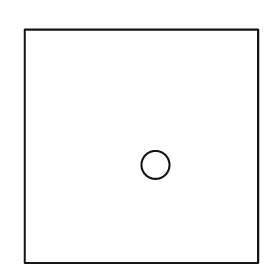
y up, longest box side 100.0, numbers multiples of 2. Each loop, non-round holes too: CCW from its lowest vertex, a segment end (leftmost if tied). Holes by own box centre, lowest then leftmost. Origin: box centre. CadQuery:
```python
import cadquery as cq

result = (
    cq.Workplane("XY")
    .moveTo(-50.0, -50.0)
    .lineTo(50.0, -50.0)
    .lineTo(50.0, 50.0)
    .lineTo(-50.0, 50.0)
    .close()
    .moveTo(6.0, -8.0)
    .circle(6.0)
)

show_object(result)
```